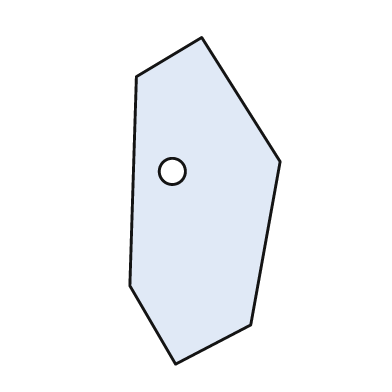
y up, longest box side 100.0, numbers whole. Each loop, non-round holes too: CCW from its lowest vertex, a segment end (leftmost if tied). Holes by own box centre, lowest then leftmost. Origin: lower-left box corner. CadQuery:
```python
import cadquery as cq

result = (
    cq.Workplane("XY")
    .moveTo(14.0, 0.0)
    .lineTo(37.0, 12.0)
    .lineTo(46.0, 62.0)
    .lineTo(22.0, 100.0)
    .lineTo(2.0, 88.0)
    .lineTo(0.0, 24.0)
    .close()
    .moveTo(13.0, 59.0)
    .circle(4.0)
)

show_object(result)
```